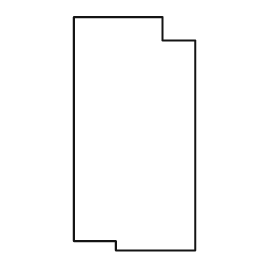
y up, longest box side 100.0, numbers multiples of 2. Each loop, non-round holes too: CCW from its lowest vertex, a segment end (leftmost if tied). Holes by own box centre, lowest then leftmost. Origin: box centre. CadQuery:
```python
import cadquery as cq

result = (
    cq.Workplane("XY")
    .moveTo(-8.0, -50.0)
    .lineTo(26.0, -50.0)
    .lineTo(26.0, 40.0)
    .lineTo(12.0, 40.0)
    .lineTo(12.0, 50.0)
    .lineTo(-26.0, 50.0)
    .lineTo(-26.0, -46.0)
    .lineTo(-8.0, -46.0)
    .close()
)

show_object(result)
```